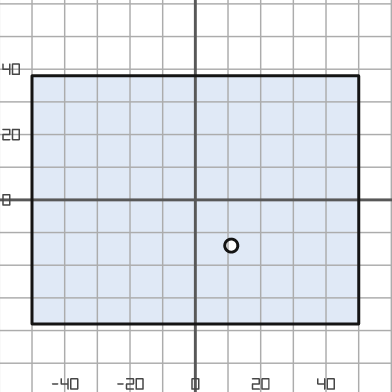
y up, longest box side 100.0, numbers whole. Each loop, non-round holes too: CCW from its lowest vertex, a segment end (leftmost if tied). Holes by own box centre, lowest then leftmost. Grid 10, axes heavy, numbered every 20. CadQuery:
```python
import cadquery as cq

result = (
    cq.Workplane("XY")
    .moveTo(-50.0, -38.0)
    .lineTo(50.0, -38.0)
    .lineTo(50.0, 38.0)
    .lineTo(-50.0, 38.0)
    .close()
    .moveTo(11.0, -14.0)
    .circle(2.0)
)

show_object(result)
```